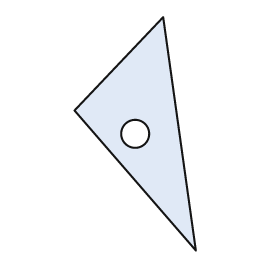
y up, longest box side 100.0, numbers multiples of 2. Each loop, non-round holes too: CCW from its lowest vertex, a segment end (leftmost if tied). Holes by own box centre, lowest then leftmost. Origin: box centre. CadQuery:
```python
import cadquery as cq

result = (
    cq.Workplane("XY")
    .moveTo(26.0, -50.0)
    .lineTo(12.0, 50.0)
    .lineTo(-26.0, 10.0)
    .close()
    .moveTo(0.0, 0.0)
    .circle(6.0)
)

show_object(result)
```